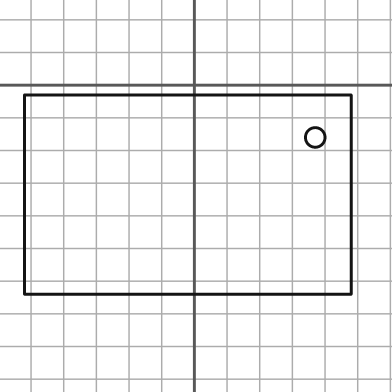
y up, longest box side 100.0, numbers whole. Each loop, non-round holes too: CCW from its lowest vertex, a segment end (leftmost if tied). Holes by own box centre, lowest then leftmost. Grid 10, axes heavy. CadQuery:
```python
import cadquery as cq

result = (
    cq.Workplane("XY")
    .moveTo(-52.0, -64.0)
    .lineTo(48.0, -64.0)
    .lineTo(48.0, -3.0)
    .lineTo(-52.0, -3.0)
    .close()
    .moveTo(37.0, -16.0)
    .circle(3.0)
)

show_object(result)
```